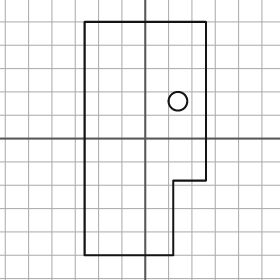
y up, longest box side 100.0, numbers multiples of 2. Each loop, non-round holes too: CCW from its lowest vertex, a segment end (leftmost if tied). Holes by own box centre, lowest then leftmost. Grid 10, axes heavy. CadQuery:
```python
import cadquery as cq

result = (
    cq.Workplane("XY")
    .moveTo(-26.0, -50.0)
    .lineTo(12.0, -50.0)
    .lineTo(12.0, -18.0)
    .lineTo(26.0, -18.0)
    .lineTo(26.0, 50.0)
    .lineTo(-26.0, 50.0)
    .close()
    .moveTo(14.0, 16.0)
    .circle(4.0)
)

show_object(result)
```